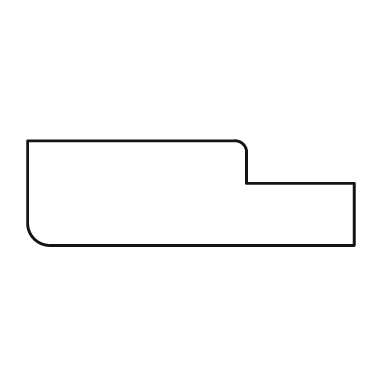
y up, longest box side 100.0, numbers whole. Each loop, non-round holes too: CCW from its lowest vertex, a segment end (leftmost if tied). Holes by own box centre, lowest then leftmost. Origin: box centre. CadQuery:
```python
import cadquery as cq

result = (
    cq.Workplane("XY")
    .moveTo(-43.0, -16.0)
    .lineTo(50.0, -16.0)
    .lineTo(50.0, 3.0)
    .lineTo(17.0, 3.0)
    .lineTo(17.0, 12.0)
    .threePointArc((16.0, 15.0), (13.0, 16.0))
    .lineTo(-50.0, 16.0)
    .lineTo(-50.0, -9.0)
    .threePointArc((-48.0, -14.0), (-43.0, -16.0))
    .close()
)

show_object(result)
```